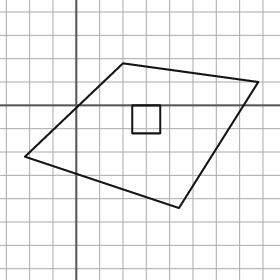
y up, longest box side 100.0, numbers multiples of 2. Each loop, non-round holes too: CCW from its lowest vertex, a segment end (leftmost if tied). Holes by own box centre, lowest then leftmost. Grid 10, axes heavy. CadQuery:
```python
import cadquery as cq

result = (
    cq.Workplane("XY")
    .moveTo(44.0, -44.0)
    .lineTo(78.0, 10.0)
    .lineTo(20.0, 18.0)
    .lineTo(-22.0, -22.0)
    .close()
    .moveTo(24.0, -12.0)
    .lineTo(36.0, -12.0)
    .lineTo(36.0, 0.0)
    .lineTo(24.0, 0.0)
    .close()
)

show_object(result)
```